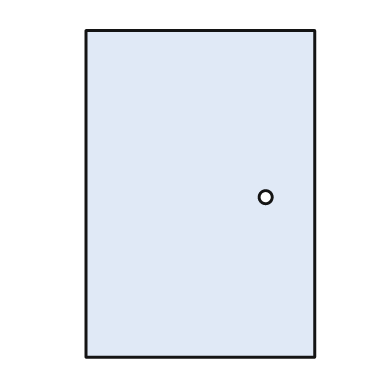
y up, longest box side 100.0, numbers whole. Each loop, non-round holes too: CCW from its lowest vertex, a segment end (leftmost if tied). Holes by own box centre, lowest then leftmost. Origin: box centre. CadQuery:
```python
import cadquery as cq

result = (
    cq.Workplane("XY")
    .moveTo(-35.0, -50.0)
    .lineTo(35.0, -50.0)
    .lineTo(35.0, 50.0)
    .lineTo(-35.0, 50.0)
    .close()
    .moveTo(20.0, -1.0)
    .circle(2.0)
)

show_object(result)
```